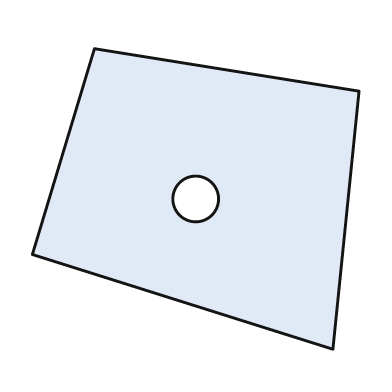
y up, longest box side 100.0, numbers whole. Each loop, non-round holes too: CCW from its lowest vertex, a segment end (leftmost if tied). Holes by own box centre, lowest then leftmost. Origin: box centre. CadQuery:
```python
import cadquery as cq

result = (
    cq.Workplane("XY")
    .moveTo(42.0, -46.0)
    .lineTo(50.0, 33.0)
    .lineTo(-31.0, 46.0)
    .lineTo(-50.0, -17.0)
    .close()
    .moveTo(0.0, 0.0)
    .circle(7.0)
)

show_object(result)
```